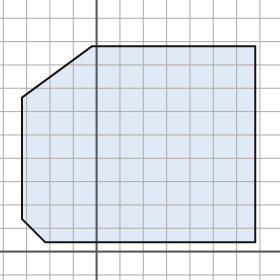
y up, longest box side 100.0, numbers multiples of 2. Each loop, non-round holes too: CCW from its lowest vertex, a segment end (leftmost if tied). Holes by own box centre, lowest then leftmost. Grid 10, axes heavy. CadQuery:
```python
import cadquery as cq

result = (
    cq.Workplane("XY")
    .moveTo(-22.0, 4.0)
    .lineTo(68.0, 4.0)
    .lineTo(68.0, 88.0)
    .lineTo(-2.0, 88.0)
    .lineTo(-32.0, 66.0)
    .lineTo(-32.0, 14.0)
    .close()
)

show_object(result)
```